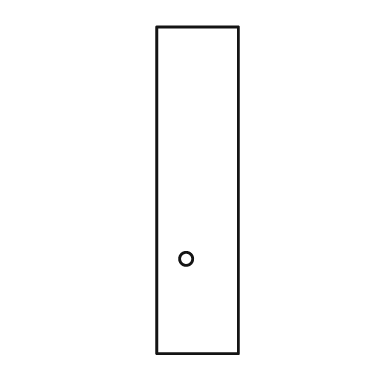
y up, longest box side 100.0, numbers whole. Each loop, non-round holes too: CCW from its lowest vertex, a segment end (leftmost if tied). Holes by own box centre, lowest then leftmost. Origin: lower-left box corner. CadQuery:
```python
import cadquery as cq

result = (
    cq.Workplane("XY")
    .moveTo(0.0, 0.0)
    .lineTo(25.0, 0.0)
    .lineTo(25.0, 100.0)
    .lineTo(0.0, 100.0)
    .close()
    .moveTo(9.0, 29.0)
    .circle(2.0)
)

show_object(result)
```